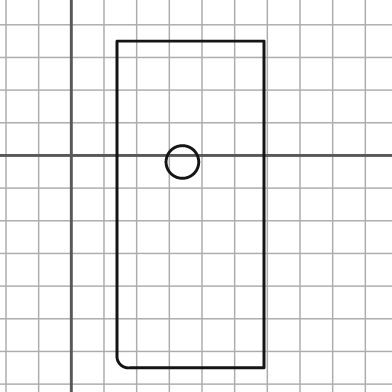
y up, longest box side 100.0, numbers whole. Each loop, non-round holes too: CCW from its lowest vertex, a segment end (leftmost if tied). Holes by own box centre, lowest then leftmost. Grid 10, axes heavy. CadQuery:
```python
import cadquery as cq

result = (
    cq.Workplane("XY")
    .moveTo(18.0, -65.0)
    .lineTo(59.0, -65.0)
    .lineTo(59.0, 35.0)
    .lineTo(14.0, 35.0)
    .lineTo(14.0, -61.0)
    .threePointArc((15.0, -64.0), (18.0, -65.0))
    .close()
    .moveTo(34.0, -2.0)
    .circle(5.0)
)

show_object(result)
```